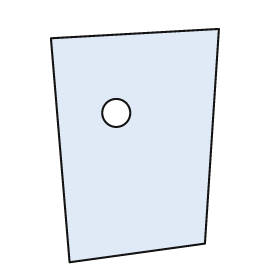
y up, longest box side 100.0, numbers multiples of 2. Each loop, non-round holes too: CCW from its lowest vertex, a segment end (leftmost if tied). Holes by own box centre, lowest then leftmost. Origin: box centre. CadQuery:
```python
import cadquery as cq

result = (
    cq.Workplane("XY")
    .moveTo(-28.0, -50.0)
    .lineTo(30.0, -42.0)
    .lineTo(36.0, 50.0)
    .lineTo(-36.0, 46.0)
    .close()
    .moveTo(-8.0, 14.0)
    .circle(6.0)
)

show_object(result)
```